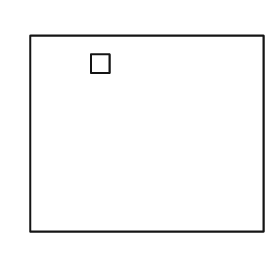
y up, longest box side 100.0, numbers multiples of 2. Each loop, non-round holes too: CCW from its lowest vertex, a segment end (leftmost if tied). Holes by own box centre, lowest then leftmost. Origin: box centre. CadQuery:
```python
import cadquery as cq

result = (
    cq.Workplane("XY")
    .moveTo(-50.0, -42.0)
    .lineTo(50.0, -42.0)
    .lineTo(50.0, 42.0)
    .lineTo(-50.0, 42.0)
    .close()
    .moveTo(-24.0, 26.0)
    .lineTo(-16.0, 26.0)
    .lineTo(-16.0, 34.0)
    .lineTo(-24.0, 34.0)
    .close()
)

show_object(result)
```